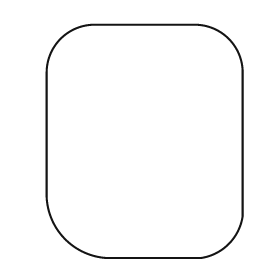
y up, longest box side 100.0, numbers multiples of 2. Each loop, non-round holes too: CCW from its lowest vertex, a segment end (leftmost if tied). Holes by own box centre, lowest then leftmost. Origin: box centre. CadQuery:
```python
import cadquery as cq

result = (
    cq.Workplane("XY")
    .moveTo(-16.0, -50.0)
    .lineTo(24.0, -50.0)
    .threePointArc((36.0, -44.0), (42.0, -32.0))
    .lineTo(42.0, 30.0)
    .threePointArc((36.0, 44.0), (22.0, 50.0))
    .lineTo(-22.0, 50.0)
    .threePointArc((-36.0, 44.0), (-42.0, 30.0))
    .lineTo(-42.0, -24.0)
    .threePointArc((-34.0, -42.0), (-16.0, -50.0))
    .close()
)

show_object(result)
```